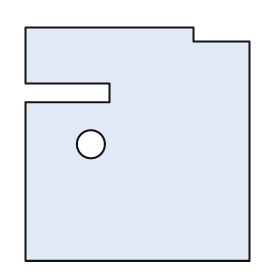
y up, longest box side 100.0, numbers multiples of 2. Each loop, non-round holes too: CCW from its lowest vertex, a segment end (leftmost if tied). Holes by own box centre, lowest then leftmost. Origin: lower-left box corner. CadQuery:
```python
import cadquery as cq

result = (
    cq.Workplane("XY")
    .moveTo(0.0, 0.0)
    .lineTo(96.0, 0.0)
    .lineTo(96.0, 94.0)
    .lineTo(72.0, 94.0)
    .lineTo(72.0, 100.0)
    .lineTo(0.0, 100.0)
    .lineTo(0.0, 76.0)
    .lineTo(36.0, 76.0)
    .lineTo(36.0, 68.0)
    .lineTo(0.0, 68.0)
    .close()
    .moveTo(28.0, 50.0)
    .circle(6.0)
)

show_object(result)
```